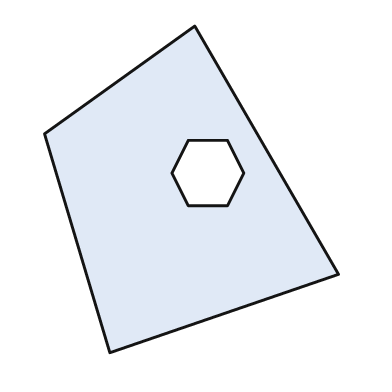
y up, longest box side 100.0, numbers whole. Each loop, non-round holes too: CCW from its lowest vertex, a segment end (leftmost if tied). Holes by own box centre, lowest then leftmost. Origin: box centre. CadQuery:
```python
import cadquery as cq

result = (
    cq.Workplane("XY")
    .moveTo(-25.0, -50.0)
    .lineTo(45.0, -26.0)
    .lineTo(1.0, 50.0)
    .lineTo(-45.0, 17.0)
    .close()
    .moveTo(-1.0, -5.0)
    .lineTo(11.0, -5.0)
    .lineTo(16.0, 5.0)
    .lineTo(11.0, 15.0)
    .lineTo(-1.0, 15.0)
    .lineTo(-6.0, 5.0)
    .close()
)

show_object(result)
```